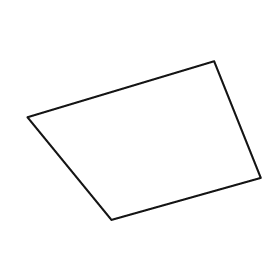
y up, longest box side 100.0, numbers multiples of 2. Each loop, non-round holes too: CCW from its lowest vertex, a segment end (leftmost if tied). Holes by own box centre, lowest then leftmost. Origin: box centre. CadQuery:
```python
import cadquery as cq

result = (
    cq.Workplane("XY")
    .moveTo(-14.0, -34.0)
    .lineTo(50.0, -16.0)
    .lineTo(30.0, 34.0)
    .lineTo(-50.0, 10.0)
    .close()
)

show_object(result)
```